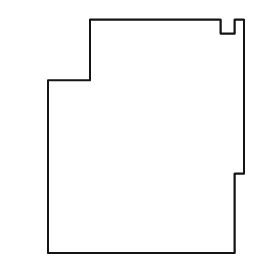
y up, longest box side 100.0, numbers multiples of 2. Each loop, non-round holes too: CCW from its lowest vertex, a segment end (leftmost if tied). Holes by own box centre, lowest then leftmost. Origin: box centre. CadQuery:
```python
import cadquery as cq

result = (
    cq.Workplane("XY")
    .moveTo(-42.0, -50.0)
    .lineTo(38.0, -50.0)
    .lineTo(38.0, -16.0)
    .lineTo(42.0, -16.0)
    .lineTo(42.0, 50.0)
    .lineTo(38.0, 50.0)
    .lineTo(38.0, 44.0)
    .lineTo(32.0, 44.0)
    .lineTo(32.0, 50.0)
    .lineTo(-24.0, 50.0)
    .lineTo(-24.0, 24.0)
    .lineTo(-42.0, 24.0)
    .close()
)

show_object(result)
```